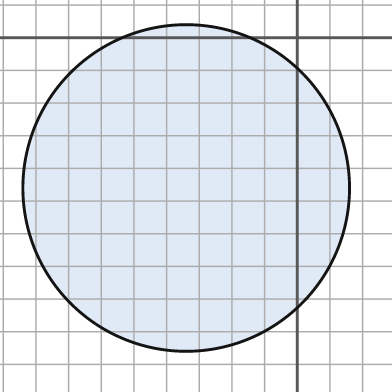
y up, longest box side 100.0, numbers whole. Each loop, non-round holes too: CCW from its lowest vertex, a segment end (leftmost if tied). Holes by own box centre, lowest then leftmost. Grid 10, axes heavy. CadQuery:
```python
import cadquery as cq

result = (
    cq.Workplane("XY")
    .moveTo(-34.0, -46.0)
    .circle(50.0)
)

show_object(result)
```